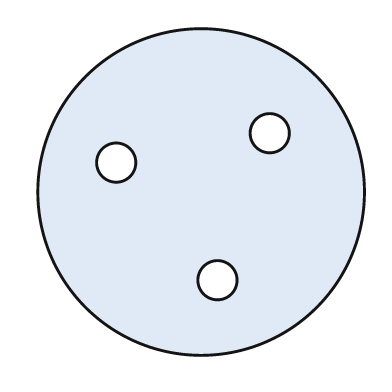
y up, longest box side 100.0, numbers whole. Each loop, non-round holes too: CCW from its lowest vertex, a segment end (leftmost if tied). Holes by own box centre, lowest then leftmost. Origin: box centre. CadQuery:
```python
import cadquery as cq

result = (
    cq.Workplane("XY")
    .moveTo(0.0, 0.0)
    .circle(50.0)
    .moveTo(5.0, -27.0)
    .circle(6.0)
    .moveTo(-26.0, 9.0)
    .circle(6.0)
    .moveTo(21.0, 18.0)
    .circle(6.0)
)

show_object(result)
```